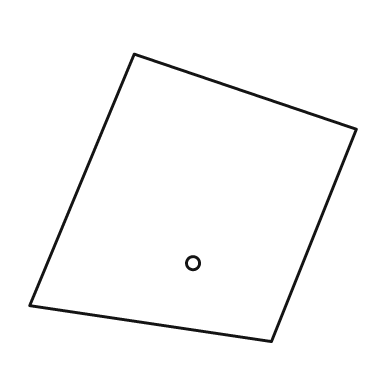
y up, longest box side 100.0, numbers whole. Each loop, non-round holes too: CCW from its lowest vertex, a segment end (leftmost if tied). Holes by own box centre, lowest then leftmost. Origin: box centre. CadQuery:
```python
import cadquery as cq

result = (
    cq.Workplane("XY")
    .moveTo(24.0, -44.0)
    .lineTo(50.0, 21.0)
    .lineTo(-18.0, 44.0)
    .lineTo(-50.0, -33.0)
    .close()
    .moveTo(0.0, -20.0)
    .circle(2.0)
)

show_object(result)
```